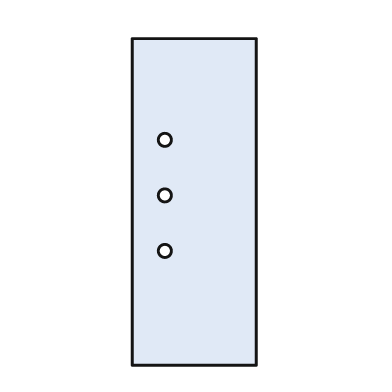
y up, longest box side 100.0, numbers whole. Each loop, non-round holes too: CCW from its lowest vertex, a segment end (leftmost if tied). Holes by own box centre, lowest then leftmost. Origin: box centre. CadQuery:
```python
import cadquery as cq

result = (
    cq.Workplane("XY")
    .moveTo(-19.0, -50.0)
    .lineTo(19.0, -50.0)
    .lineTo(19.0, 50.0)
    .lineTo(-19.0, 50.0)
    .close()
    .moveTo(-9.0, -15.0)
    .circle(2.0)
    .moveTo(-9.0, 2.0)
    .circle(2.0)
    .moveTo(-9.0, 19.0)
    .circle(2.0)
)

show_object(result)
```